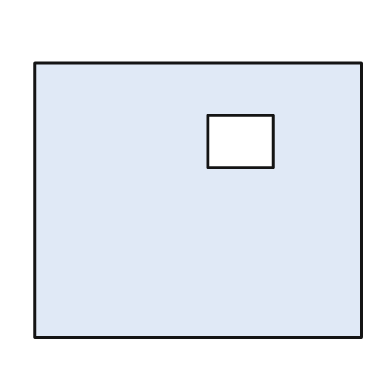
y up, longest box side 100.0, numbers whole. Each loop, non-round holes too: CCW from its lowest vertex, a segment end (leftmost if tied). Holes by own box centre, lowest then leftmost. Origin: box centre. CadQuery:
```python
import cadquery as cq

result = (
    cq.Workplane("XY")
    .moveTo(-50.0, -42.0)
    .lineTo(50.0, -42.0)
    .lineTo(50.0, 42.0)
    .lineTo(-50.0, 42.0)
    .close()
    .moveTo(3.0, 10.0)
    .lineTo(23.0, 10.0)
    .lineTo(23.0, 26.0)
    .lineTo(3.0, 26.0)
    .close()
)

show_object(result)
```